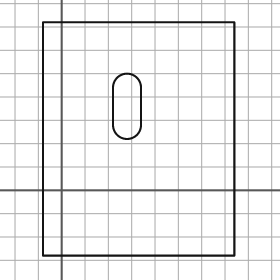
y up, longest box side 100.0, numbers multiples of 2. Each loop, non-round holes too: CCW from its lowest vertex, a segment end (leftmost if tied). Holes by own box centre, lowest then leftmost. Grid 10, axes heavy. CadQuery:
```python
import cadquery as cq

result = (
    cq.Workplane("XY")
    .moveTo(-8.0, -28.0)
    .lineTo(74.0, -28.0)
    .lineTo(74.0, 72.0)
    .lineTo(-8.0, 72.0)
    .close()
    .moveTo(22.0, 28.0)
    .threePointArc((28.0, 22.0), (34.0, 28.0))
    .lineTo(34.0, 44.0)
    .threePointArc((28.0, 50.0), (22.0, 44.0))
    .close()
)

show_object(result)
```